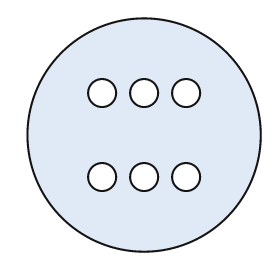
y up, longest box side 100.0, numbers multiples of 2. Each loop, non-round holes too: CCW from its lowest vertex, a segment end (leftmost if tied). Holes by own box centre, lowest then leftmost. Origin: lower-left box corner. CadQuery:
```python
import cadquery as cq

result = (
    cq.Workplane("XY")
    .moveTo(50.0, 50.0)
    .circle(50.0)
    .moveTo(32.0, 32.0)
    .circle(6.0)
    .moveTo(50.0, 32.0)
    .circle(6.0)
    .moveTo(68.0, 32.0)
    .circle(6.0)
    .moveTo(32.0, 68.0)
    .circle(6.0)
    .moveTo(50.0, 68.0)
    .circle(6.0)
    .moveTo(68.0, 68.0)
    .circle(6.0)
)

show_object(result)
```